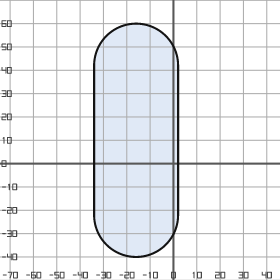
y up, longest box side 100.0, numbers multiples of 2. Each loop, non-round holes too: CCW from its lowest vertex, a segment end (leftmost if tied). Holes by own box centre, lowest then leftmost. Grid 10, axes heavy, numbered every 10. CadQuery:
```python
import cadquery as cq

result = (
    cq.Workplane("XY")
    .moveTo(-34.0, -22.0)
    .threePointArc((-16.0, -40.0), (2.0, -22.0))
    .lineTo(2.0, 42.0)
    .threePointArc((-16.0, 60.0), (-34.0, 42.0))
    .close()
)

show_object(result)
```